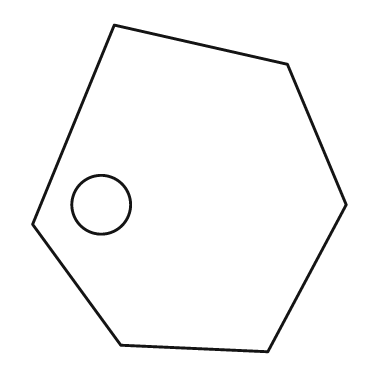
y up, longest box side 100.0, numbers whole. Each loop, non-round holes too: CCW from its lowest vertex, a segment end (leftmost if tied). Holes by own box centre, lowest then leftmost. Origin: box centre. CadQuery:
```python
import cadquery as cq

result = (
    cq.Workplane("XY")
    .moveTo(24.0, -50.0)
    .lineTo(48.0, -5.0)
    .lineTo(30.0, 38.0)
    .lineTo(-23.0, 50.0)
    .lineTo(-48.0, -11.0)
    .lineTo(-21.0, -48.0)
    .close()
    .moveTo(-27.0, -5.0)
    .circle(9.0)
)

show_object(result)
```